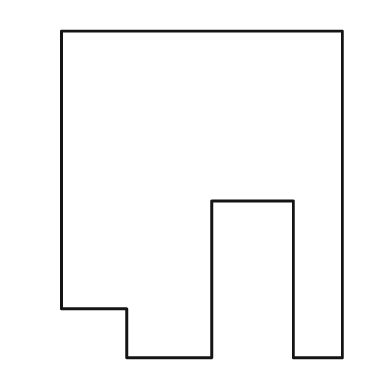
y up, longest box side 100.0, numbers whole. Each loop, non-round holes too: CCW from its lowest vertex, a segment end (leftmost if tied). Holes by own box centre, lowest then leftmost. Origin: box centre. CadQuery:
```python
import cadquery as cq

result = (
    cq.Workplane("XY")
    .moveTo(-23.0, -50.0)
    .lineTo(3.0, -50.0)
    .lineTo(3.0, -2.0)
    .lineTo(28.0, -2.0)
    .lineTo(28.0, -50.0)
    .lineTo(43.0, -50.0)
    .lineTo(43.0, 50.0)
    .lineTo(-43.0, 50.0)
    .lineTo(-43.0, -35.0)
    .lineTo(-23.0, -35.0)
    .close()
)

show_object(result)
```